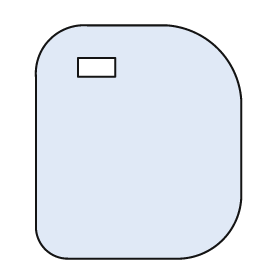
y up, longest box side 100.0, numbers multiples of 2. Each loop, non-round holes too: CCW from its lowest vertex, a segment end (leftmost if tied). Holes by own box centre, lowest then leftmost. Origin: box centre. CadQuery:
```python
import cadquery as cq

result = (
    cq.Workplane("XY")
    .moveTo(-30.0, -50.0)
    .lineTo(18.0, -50.0)
    .threePointArc((36.0, -42.0), (44.0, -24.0))
    .lineTo(44.0, 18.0)
    .threePointArc((34.0, 40.0), (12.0, 50.0))
    .lineTo(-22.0, 50.0)
    .threePointArc((-38.0, 44.0), (-44.0, 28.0))
    .lineTo(-44.0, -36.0)
    .threePointArc((-40.0, -46.0), (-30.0, -50.0))
    .close()
    .moveTo(-26.0, 28.0)
    .lineTo(-10.0, 28.0)
    .lineTo(-10.0, 36.0)
    .lineTo(-26.0, 36.0)
    .close()
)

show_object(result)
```